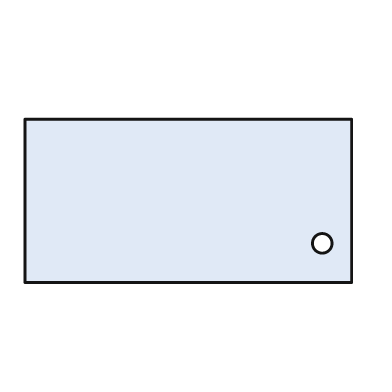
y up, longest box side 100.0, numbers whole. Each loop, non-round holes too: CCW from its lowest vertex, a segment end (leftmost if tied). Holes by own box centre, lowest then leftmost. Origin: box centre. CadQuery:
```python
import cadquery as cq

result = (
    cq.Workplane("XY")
    .moveTo(-50.0, -25.0)
    .lineTo(50.0, -25.0)
    .lineTo(50.0, 25.0)
    .lineTo(-50.0, 25.0)
    .close()
    .moveTo(41.0, -13.0)
    .circle(3.0)
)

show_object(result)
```